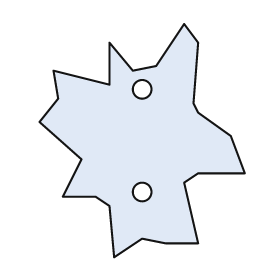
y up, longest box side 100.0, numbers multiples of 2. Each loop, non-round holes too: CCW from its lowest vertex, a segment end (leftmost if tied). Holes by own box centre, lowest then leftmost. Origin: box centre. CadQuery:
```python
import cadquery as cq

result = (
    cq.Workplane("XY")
    .moveTo(-12.0, -50.0)
    .lineTo(0.0, -42.0)
    .lineTo(10.0, -44.0)
    .lineTo(24.0, -44.0)
    .lineTo(18.0, -18.0)
    .lineTo(24.0, -14.0)
    .lineTo(44.0, -14.0)
    .lineTo(38.0, 2.0)
    .lineTo(24.0, 12.0)
    .lineTo(22.0, 16.0)
    .lineTo(24.0, 42.0)
    .lineTo(18.0, 50.0)
    .lineTo(6.0, 32.0)
    .lineTo(-4.0, 30.0)
    .lineTo(-14.0, 42.0)
    .lineTo(-14.0, 24.0)
    .lineTo(-38.0, 30.0)
    .lineTo(-36.0, 18.0)
    .lineTo(-44.0, 8.0)
    .lineTo(-26.0, -8.0)
    .lineTo(-34.0, -24.0)
    .lineTo(-20.0, -24.0)
    .lineTo(-14.0, -28.0)
    .close()
    .moveTo(0.0, -22.0)
    .circle(4.0)
    .moveTo(0.0, 22.0)
    .circle(4.0)
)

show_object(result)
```